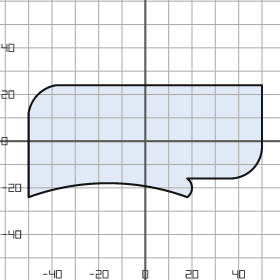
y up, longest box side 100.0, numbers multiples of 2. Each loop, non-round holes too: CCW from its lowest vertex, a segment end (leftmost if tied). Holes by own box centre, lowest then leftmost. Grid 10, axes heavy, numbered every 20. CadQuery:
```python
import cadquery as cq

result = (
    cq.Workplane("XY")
    .moveTo(-50.0, -24.0)
    .threePointArc((-16.0, -18.0), (18.0, -24.0))
    .threePointArc((20.0, -20.0), (18.0, -16.0))
    .lineTo(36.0, -16.0)
    .threePointArc((46.0, -12.0), (50.0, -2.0))
    .lineTo(50.0, 24.0)
    .lineTo(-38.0, 24.0)
    .threePointArc((-46.0, 20.0), (-50.0, 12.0))
    .close()
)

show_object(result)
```